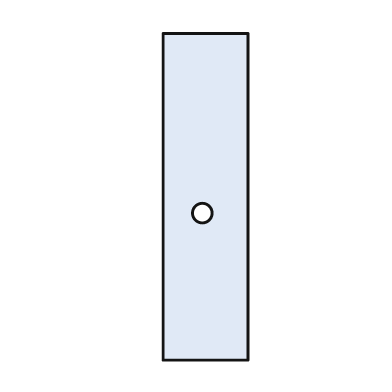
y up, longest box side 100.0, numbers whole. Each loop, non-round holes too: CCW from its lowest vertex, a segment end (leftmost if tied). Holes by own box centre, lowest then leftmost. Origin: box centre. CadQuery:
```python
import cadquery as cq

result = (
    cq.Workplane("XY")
    .moveTo(-13.0, -50.0)
    .lineTo(13.0, -50.0)
    .lineTo(13.0, 50.0)
    .lineTo(-13.0, 50.0)
    .close()
    .moveTo(-1.0, -5.0)
    .circle(3.0)
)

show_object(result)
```